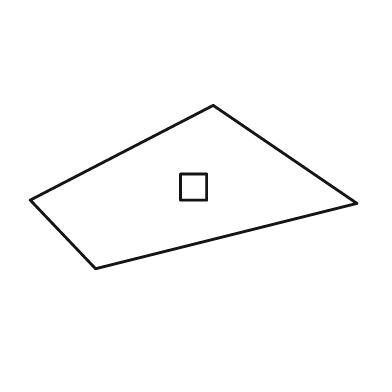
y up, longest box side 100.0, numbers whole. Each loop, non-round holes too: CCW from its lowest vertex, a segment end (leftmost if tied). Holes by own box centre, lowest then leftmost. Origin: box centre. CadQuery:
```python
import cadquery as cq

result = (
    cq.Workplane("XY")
    .moveTo(-30.0, -25.0)
    .lineTo(50.0, -5.0)
    .lineTo(6.0, 25.0)
    .lineTo(-50.0, -4.0)
    .close()
    .moveTo(-4.0, -4.0)
    .lineTo(4.0, -4.0)
    .lineTo(4.0, 4.0)
    .lineTo(-4.0, 4.0)
    .close()
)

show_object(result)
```